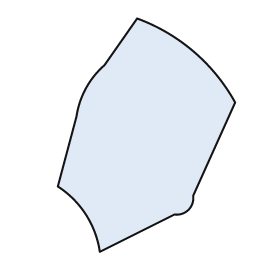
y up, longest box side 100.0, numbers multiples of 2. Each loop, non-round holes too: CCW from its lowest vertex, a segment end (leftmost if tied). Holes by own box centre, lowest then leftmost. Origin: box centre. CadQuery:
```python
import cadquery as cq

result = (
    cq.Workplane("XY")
    .moveTo(-20.0, -50.0)
    .lineTo(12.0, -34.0)
    .threePointArc((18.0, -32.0), (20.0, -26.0))
    .lineTo(38.0, 14.0)
    .threePointArc((20.0, 36.0), (-4.0, 50.0))
    .lineTo(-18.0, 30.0)
    .threePointArc((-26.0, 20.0), (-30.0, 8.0))
    .lineTo(-38.0, -22.0)
    .threePointArc((-26.0, -34.0), (-20.0, -50.0))
    .close()
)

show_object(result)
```